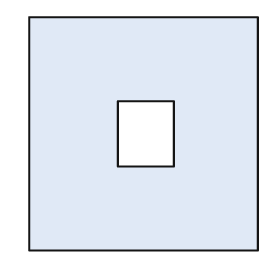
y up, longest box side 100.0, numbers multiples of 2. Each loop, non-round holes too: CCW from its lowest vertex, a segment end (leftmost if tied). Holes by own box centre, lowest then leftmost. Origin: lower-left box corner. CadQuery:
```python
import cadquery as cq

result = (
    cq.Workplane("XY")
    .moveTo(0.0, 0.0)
    .lineTo(98.0, 0.0)
    .lineTo(98.0, 100.0)
    .lineTo(0.0, 100.0)
    .close()
    .moveTo(38.0, 36.0)
    .lineTo(62.0, 36.0)
    .lineTo(62.0, 64.0)
    .lineTo(38.0, 64.0)
    .close()
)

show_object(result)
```